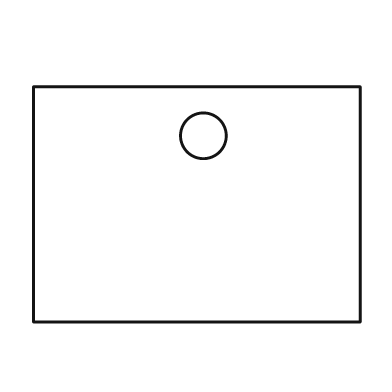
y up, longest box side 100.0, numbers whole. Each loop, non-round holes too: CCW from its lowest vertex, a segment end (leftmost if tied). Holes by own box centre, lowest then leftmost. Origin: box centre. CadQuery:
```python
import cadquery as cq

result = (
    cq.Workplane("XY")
    .moveTo(-50.0, -36.0)
    .lineTo(50.0, -36.0)
    .lineTo(50.0, 36.0)
    .lineTo(-50.0, 36.0)
    .close()
    .moveTo(2.0, 21.0)
    .circle(7.0)
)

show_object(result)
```